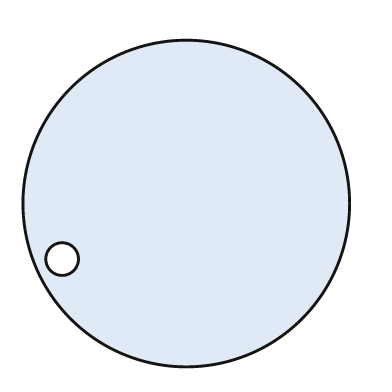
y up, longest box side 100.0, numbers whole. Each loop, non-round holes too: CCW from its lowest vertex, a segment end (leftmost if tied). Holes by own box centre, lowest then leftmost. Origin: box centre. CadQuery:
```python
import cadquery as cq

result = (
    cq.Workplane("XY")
    .moveTo(0.0, 0.0)
    .circle(50.0)
    .moveTo(-38.0, -17.0)
    .circle(5.0)
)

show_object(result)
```